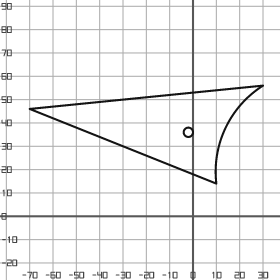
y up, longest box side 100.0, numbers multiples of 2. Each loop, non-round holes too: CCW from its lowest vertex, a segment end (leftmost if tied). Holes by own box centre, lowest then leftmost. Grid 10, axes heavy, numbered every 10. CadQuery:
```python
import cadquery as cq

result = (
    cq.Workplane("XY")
    .moveTo(10.0, 14.0)
    .threePointArc((14.0, 38.0), (30.0, 56.0))
    .lineTo(-70.0, 46.0)
    .close()
    .moveTo(-2.0, 36.0)
    .circle(2.0)
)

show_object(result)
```